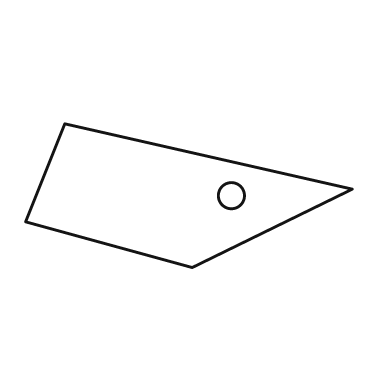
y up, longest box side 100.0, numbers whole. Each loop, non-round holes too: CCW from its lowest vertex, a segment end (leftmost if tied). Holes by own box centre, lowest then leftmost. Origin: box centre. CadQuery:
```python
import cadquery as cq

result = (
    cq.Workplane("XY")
    .moveTo(1.0, -22.0)
    .lineTo(50.0, 2.0)
    .lineTo(-38.0, 22.0)
    .lineTo(-50.0, -8.0)
    .close()
    .moveTo(13.0, 0.0)
    .circle(4.0)
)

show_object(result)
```